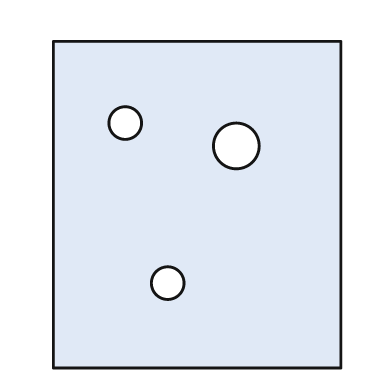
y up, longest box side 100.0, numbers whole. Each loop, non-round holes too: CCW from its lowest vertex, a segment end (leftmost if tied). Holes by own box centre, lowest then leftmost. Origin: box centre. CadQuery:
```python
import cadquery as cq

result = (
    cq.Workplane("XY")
    .moveTo(-44.0, -50.0)
    .lineTo(44.0, -50.0)
    .lineTo(44.0, 50.0)
    .lineTo(-44.0, 50.0)
    .close()
    .moveTo(-9.0, -24.0)
    .circle(5.0)
    .moveTo(12.0, 18.0)
    .circle(7.0)
    .moveTo(-22.0, 25.0)
    .circle(5.0)
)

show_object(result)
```